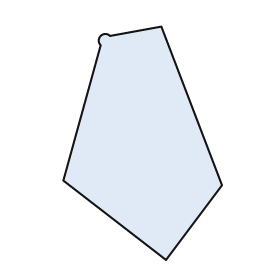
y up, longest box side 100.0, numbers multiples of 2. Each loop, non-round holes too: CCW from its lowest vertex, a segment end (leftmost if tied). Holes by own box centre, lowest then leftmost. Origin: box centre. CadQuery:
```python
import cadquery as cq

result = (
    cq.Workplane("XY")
    .moveTo(10.0, -50.0)
    .lineTo(34.0, -18.0)
    .lineTo(8.0, 50.0)
    .lineTo(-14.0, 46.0)
    .threePointArc((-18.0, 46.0), (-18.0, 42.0))
    .lineTo(-34.0, -16.0)
    .close()
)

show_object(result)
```